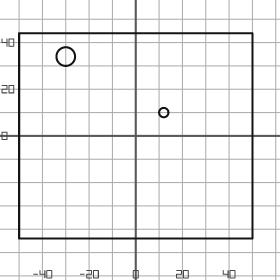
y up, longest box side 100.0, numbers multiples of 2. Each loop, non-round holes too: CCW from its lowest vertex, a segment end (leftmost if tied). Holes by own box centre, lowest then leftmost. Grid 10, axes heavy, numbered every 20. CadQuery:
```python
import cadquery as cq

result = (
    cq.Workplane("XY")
    .moveTo(-50.0, -44.0)
    .lineTo(50.0, -44.0)
    .lineTo(50.0, 44.0)
    .lineTo(-50.0, 44.0)
    .close()
    .moveTo(12.0, 10.0)
    .circle(2.0)
    .moveTo(-30.0, 34.0)
    .circle(4.0)
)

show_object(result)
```